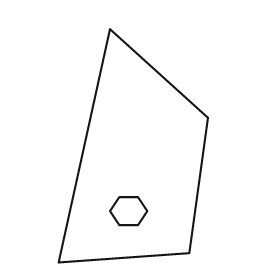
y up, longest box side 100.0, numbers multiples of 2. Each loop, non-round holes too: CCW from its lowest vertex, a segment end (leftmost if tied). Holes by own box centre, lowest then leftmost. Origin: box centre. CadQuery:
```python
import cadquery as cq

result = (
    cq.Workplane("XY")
    .moveTo(-32.0, -50.0)
    .lineTo(24.0, -46.0)
    .lineTo(32.0, 12.0)
    .lineTo(-10.0, 50.0)
    .close()
    .moveTo(-6.0, -34.0)
    .lineTo(2.0, -34.0)
    .lineTo(6.0, -28.0)
    .lineTo(2.0, -22.0)
    .lineTo(-6.0, -22.0)
    .lineTo(-10.0, -28.0)
    .close()
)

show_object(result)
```